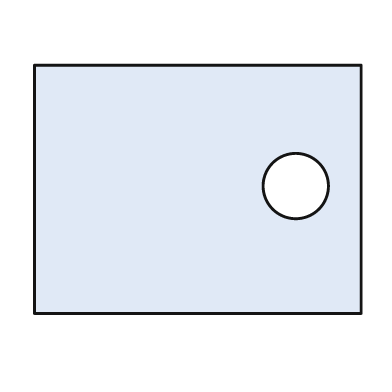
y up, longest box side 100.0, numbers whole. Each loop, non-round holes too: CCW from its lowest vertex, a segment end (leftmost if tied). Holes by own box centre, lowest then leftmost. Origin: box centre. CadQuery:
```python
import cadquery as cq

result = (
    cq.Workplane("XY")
    .moveTo(-50.0, -38.0)
    .lineTo(50.0, -38.0)
    .lineTo(50.0, 38.0)
    .lineTo(-50.0, 38.0)
    .close()
    .moveTo(30.0, 1.0)
    .circle(10.0)
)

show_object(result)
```